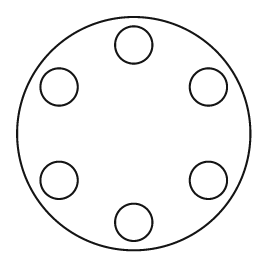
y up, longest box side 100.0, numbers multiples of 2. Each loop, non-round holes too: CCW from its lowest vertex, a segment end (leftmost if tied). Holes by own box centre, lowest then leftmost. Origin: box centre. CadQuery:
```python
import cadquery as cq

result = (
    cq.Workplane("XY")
    .moveTo(0.0, 0.0)
    .circle(50.0)
    .moveTo(0.0, -38.0)
    .circle(8.0)
    .moveTo(-32.0, -20.0)
    .circle(8.0)
    .moveTo(32.0, -20.0)
    .circle(8.0)
    .moveTo(-32.0, 20.0)
    .circle(8.0)
    .moveTo(32.0, 20.0)
    .circle(8.0)
    .moveTo(0.0, 38.0)
    .circle(8.0)
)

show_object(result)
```